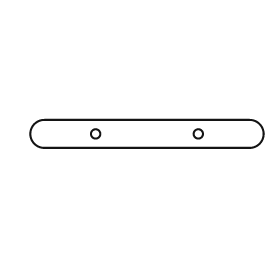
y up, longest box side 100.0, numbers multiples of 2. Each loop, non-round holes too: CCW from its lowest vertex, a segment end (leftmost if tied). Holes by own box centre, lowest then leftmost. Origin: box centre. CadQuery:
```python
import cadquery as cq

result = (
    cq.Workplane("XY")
    .moveTo(-44.0, -6.0)
    .lineTo(44.0, -6.0)
    .threePointArc((50.0, 0.0), (44.0, 6.0))
    .lineTo(-44.0, 6.0)
    .threePointArc((-50.0, 0.0), (-44.0, -6.0))
    .close()
    .moveTo(-22.0, 0.0)
    .circle(2.0)
    .moveTo(22.0, 0.0)
    .circle(2.0)
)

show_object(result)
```